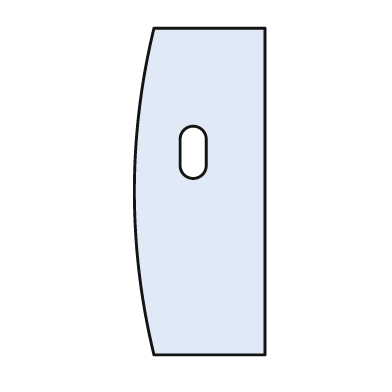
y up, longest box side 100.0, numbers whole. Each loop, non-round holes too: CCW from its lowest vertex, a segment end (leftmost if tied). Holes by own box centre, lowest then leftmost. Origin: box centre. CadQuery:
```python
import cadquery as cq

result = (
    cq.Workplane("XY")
    .moveTo(-14.0, -50.0)
    .lineTo(20.0, -50.0)
    .lineTo(20.0, 50.0)
    .lineTo(-14.0, 50.0)
    .threePointArc((-20.0, 0.0), (-14.0, -50.0))
    .close()
    .moveTo(-6.0, 8.0)
    .threePointArc((-2.0, 4.0), (2.0, 8.0))
    .lineTo(2.0, 16.0)
    .threePointArc((-2.0, 20.0), (-6.0, 16.0))
    .close()
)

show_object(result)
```